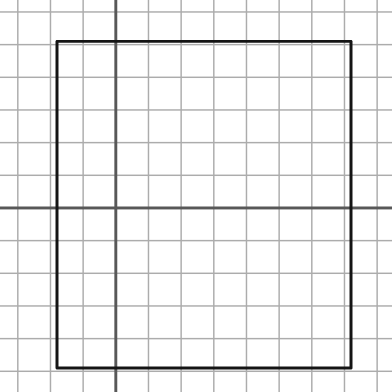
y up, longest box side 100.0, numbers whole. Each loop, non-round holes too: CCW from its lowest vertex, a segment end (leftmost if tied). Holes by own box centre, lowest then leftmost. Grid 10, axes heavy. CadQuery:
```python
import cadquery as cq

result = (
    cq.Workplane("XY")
    .moveTo(-18.0, -49.0)
    .lineTo(72.0, -49.0)
    .lineTo(72.0, 51.0)
    .lineTo(-18.0, 51.0)
    .close()
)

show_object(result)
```